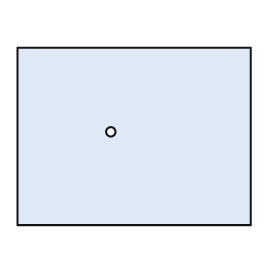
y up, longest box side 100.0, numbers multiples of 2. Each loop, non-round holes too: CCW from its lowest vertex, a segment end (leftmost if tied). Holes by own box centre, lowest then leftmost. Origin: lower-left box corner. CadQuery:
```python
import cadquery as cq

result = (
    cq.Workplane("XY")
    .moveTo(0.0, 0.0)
    .lineTo(100.0, 0.0)
    .lineTo(100.0, 76.0)
    .lineTo(0.0, 76.0)
    .close()
    .moveTo(40.0, 40.0)
    .circle(2.0)
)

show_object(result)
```